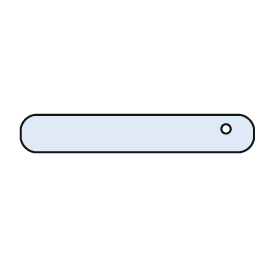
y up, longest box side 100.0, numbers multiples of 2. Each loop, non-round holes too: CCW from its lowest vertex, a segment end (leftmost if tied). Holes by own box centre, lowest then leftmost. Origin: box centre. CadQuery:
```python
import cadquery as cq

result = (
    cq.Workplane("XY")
    .moveTo(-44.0, -8.0)
    .lineTo(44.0, -8.0)
    .threePointArc((48.0, -6.0), (50.0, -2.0))
    .lineTo(50.0, 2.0)
    .threePointArc((48.0, 6.0), (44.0, 8.0))
    .lineTo(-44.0, 8.0)
    .threePointArc((-48.0, 6.0), (-50.0, 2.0))
    .lineTo(-50.0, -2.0)
    .threePointArc((-48.0, -6.0), (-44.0, -8.0))
    .close()
    .moveTo(38.0, 2.0)
    .circle(2.0)
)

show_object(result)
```